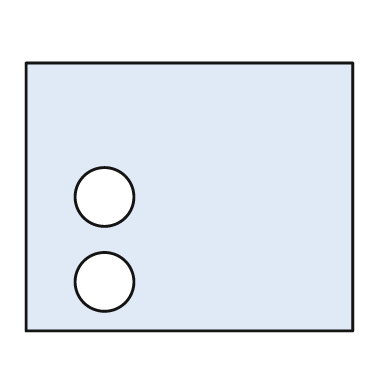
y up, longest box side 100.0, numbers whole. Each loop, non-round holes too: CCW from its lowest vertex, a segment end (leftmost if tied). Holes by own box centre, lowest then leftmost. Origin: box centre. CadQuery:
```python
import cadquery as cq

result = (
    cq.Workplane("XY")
    .moveTo(-50.0, -41.0)
    .lineTo(50.0, -41.0)
    .lineTo(50.0, 41.0)
    .lineTo(-50.0, 41.0)
    .close()
    .moveTo(-26.0, -26.0)
    .circle(9.0)
    .moveTo(-26.0, 0.0)
    .circle(9.0)
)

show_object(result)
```